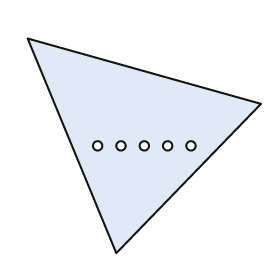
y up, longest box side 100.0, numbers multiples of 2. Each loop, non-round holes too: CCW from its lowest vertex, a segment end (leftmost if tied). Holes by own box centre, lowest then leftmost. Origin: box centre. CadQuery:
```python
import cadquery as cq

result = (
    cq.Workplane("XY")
    .moveTo(-12.0, -46.0)
    .lineTo(50.0, 18.0)
    .lineTo(-50.0, 46.0)
    .close()
    .moveTo(-20.0, 0.0)
    .circle(2.0)
    .moveTo(-10.0, 0.0)
    .circle(2.0)
    .moveTo(0.0, 0.0)
    .circle(2.0)
    .moveTo(10.0, 0.0)
    .circle(2.0)
    .moveTo(20.0, 0.0)
    .circle(2.0)
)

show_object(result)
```